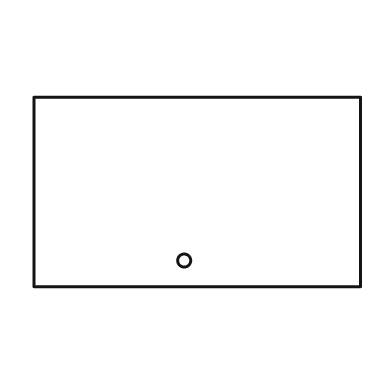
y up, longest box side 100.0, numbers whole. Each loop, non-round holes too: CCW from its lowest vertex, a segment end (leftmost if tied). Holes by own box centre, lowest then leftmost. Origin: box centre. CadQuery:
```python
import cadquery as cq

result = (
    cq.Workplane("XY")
    .moveTo(-50.0, -29.0)
    .lineTo(50.0, -29.0)
    .lineTo(50.0, 29.0)
    .lineTo(-50.0, 29.0)
    .close()
    .moveTo(-4.0, -21.0)
    .circle(2.0)
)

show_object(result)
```